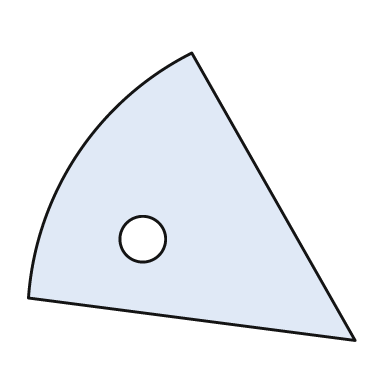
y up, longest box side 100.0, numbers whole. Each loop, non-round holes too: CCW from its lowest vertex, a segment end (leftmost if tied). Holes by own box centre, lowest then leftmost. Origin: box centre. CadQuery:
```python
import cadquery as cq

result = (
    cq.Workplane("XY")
    .moveTo(50.0, -44.0)
    .lineTo(0.0, 44.0)
    .threePointArc((-35.0, 13.0), (-50.0, -31.0))
    .close()
    .moveTo(-15.0, -13.0)
    .circle(7.0)
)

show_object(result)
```